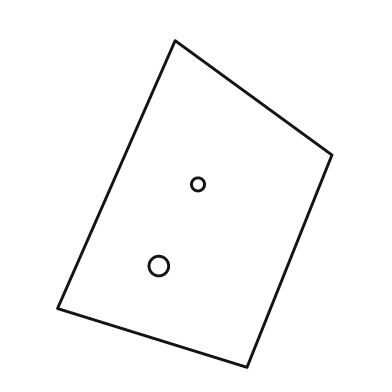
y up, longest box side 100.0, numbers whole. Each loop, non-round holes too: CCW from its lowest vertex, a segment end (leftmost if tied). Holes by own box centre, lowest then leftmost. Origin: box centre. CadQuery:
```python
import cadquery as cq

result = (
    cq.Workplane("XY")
    .moveTo(16.0, -50.0)
    .lineTo(42.0, 15.0)
    .lineTo(-6.0, 50.0)
    .lineTo(-42.0, -32.0)
    .close()
    .moveTo(-11.0, -19.0)
    .circle(3.0)
    .moveTo(1.0, 6.0)
    .circle(2.0)
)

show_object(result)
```